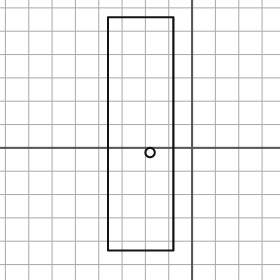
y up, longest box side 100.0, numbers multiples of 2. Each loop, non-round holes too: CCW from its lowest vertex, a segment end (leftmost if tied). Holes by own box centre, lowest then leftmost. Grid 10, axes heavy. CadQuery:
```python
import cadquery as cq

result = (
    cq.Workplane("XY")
    .moveTo(-36.0, -44.0)
    .lineTo(-8.0, -44.0)
    .lineTo(-8.0, 56.0)
    .lineTo(-36.0, 56.0)
    .close()
    .moveTo(-18.0, -2.0)
    .circle(2.0)
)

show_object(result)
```